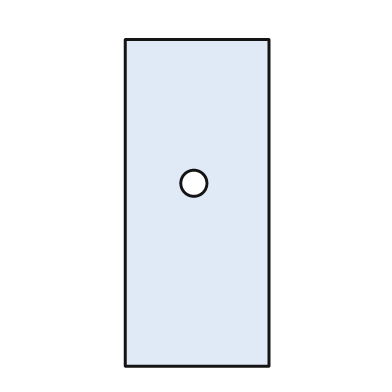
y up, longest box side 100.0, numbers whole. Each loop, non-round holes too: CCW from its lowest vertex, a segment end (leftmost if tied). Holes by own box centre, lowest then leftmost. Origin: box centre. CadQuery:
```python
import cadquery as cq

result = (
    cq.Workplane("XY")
    .moveTo(-22.0, -50.0)
    .lineTo(22.0, -50.0)
    .lineTo(22.0, 50.0)
    .lineTo(-22.0, 50.0)
    .close()
    .moveTo(-1.0, 6.0)
    .circle(4.0)
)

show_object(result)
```